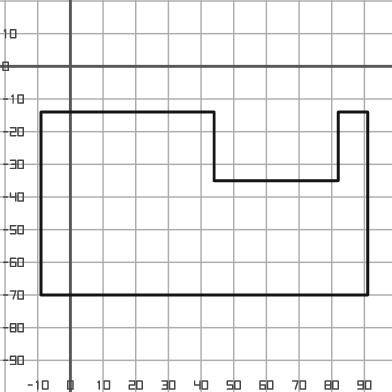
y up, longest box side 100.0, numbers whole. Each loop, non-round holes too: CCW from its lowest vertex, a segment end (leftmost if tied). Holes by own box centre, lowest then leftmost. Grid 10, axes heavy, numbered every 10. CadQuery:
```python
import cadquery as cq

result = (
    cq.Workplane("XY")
    .moveTo(-9.0, -70.0)
    .lineTo(91.0, -70.0)
    .lineTo(91.0, -14.0)
    .lineTo(82.0, -14.0)
    .lineTo(82.0, -35.0)
    .lineTo(44.0, -35.0)
    .lineTo(44.0, -14.0)
    .lineTo(-9.0, -14.0)
    .close()
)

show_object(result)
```